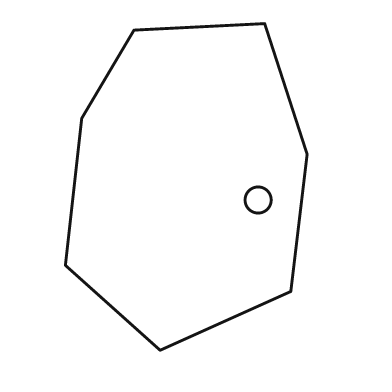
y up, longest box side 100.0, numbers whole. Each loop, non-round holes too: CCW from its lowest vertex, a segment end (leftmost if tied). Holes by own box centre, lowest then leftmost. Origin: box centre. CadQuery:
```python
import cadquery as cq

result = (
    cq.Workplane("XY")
    .moveTo(-8.0, -50.0)
    .lineTo(32.0, -32.0)
    .lineTo(37.0, 10.0)
    .lineTo(24.0, 50.0)
    .lineTo(-16.0, 48.0)
    .lineTo(-32.0, 21.0)
    .lineTo(-37.0, -24.0)
    .close()
    .moveTo(22.0, -4.0)
    .circle(4.0)
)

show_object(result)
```